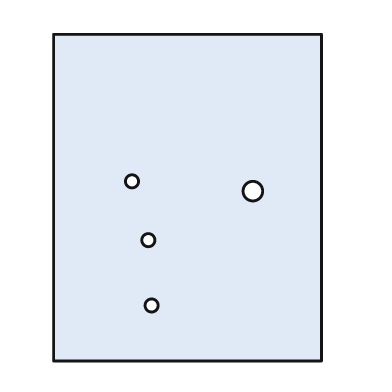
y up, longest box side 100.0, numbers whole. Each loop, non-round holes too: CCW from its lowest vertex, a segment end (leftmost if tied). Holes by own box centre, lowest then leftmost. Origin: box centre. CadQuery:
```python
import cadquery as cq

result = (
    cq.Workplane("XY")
    .moveTo(-41.0, -50.0)
    .lineTo(41.0, -50.0)
    .lineTo(41.0, 50.0)
    .lineTo(-41.0, 50.0)
    .close()
    .moveTo(-11.0, -33.0)
    .circle(2.0)
    .moveTo(-12.0, -13.0)
    .circle(2.0)
    .moveTo(20.0, 2.0)
    .circle(3.0)
    .moveTo(-17.0, 5.0)
    .circle(2.0)
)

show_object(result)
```